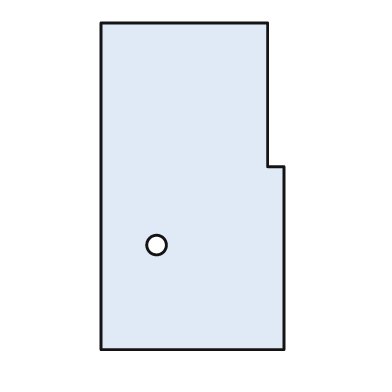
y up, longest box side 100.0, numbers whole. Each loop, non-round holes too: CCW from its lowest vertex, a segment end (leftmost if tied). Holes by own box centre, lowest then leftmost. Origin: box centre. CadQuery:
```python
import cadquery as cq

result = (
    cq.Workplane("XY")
    .moveTo(-28.0, -50.0)
    .lineTo(28.0, -50.0)
    .lineTo(28.0, 6.0)
    .lineTo(23.0, 6.0)
    .lineTo(23.0, 50.0)
    .lineTo(-28.0, 50.0)
    .close()
    .moveTo(-11.0, -18.0)
    .circle(3.0)
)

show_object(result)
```